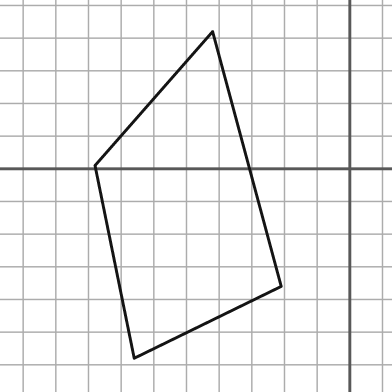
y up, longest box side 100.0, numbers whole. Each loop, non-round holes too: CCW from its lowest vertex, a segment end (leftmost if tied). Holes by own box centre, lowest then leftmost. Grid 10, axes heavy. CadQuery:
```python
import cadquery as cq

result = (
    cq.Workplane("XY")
    .moveTo(-66.0, -58.0)
    .lineTo(-21.0, -36.0)
    .lineTo(-42.0, 42.0)
    .lineTo(-78.0, 1.0)
    .close()
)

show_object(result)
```